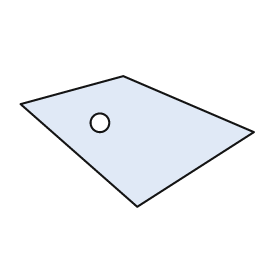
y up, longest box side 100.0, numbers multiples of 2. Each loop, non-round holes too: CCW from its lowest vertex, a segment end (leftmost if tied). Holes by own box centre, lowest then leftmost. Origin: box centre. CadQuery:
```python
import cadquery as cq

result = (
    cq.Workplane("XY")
    .moveTo(0.0, -28.0)
    .lineTo(50.0, 4.0)
    .lineTo(-6.0, 28.0)
    .lineTo(-50.0, 16.0)
    .close()
    .moveTo(-16.0, 8.0)
    .circle(4.0)
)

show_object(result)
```